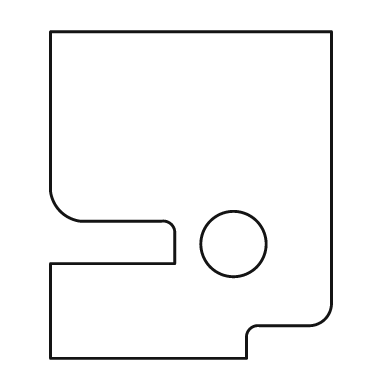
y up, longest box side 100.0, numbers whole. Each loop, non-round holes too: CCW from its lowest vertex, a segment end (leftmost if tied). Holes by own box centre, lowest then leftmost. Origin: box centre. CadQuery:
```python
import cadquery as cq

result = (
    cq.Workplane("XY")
    .moveTo(-43.0, -50.0)
    .lineTo(17.0, -50.0)
    .lineTo(17.0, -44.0)
    .threePointArc((18.0, -41.0), (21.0, -40.0))
    .lineTo(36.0, -40.0)
    .threePointArc((41.0, -38.0), (43.0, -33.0))
    .lineTo(43.0, 50.0)
    .lineTo(-43.0, 50.0)
    .lineTo(-43.0, 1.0)
    .threePointArc((-40.0, -5.0), (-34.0, -8.0))
    .lineTo(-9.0, -8.0)
    .threePointArc((-6.0, -9.0), (-5.0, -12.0))
    .lineTo(-5.0, -21.0)
    .lineTo(-43.0, -21.0)
    .close()
    .moveTo(13.0, -15.0)
    .circle(10.0)
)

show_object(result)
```